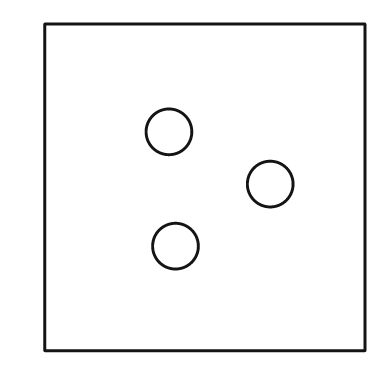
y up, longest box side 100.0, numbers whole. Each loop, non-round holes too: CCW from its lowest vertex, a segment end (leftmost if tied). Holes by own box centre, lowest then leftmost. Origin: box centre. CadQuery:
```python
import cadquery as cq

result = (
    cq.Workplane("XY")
    .moveTo(-49.0, -50.0)
    .lineTo(49.0, -50.0)
    .lineTo(49.0, 50.0)
    .lineTo(-49.0, 50.0)
    .close()
    .moveTo(-9.0, -18.0)
    .circle(7.0)
    .moveTo(20.0, 1.0)
    .circle(7.0)
    .moveTo(-11.0, 17.0)
    .circle(7.0)
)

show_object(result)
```